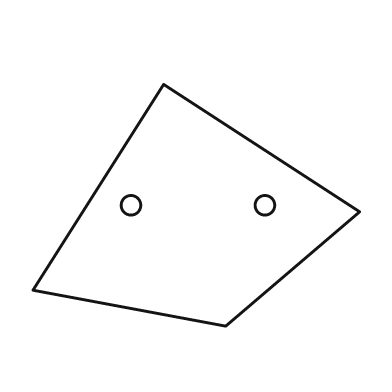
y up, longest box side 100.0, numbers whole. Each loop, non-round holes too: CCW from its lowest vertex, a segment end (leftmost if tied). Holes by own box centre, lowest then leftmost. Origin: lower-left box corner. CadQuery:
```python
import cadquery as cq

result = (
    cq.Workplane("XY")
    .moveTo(59.0, 0.0)
    .lineTo(100.0, 35.0)
    .lineTo(40.0, 74.0)
    .lineTo(0.0, 11.0)
    .close()
    .moveTo(30.0, 37.0)
    .circle(3.0)
    .moveTo(71.0, 37.0)
    .circle(3.0)
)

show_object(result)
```